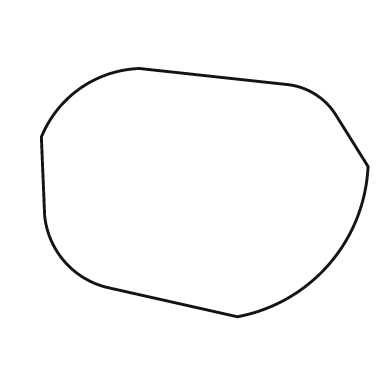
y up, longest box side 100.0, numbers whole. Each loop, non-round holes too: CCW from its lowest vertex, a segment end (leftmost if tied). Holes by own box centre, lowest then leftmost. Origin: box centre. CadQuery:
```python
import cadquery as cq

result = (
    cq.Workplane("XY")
    .moveTo(10.0, -38.0)
    .threePointArc((38.0, -22.0), (50.0, 8.0))
    .lineTo(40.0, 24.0)
    .threePointArc((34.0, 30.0), (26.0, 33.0))
    .lineTo(-20.0, 38.0)
    .threePointArc((-38.0, 32.0), (-50.0, 17.0))
    .lineTo(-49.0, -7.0)
    .threePointArc((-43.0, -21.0), (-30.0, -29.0))
    .close()
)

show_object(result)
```